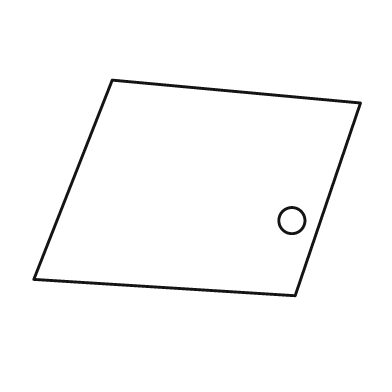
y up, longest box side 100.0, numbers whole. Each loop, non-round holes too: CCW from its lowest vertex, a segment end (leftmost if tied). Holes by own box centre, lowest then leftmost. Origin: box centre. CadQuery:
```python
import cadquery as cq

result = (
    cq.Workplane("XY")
    .moveTo(30.0, -33.0)
    .lineTo(50.0, 26.0)
    .lineTo(-26.0, 33.0)
    .lineTo(-50.0, -28.0)
    .close()
    .moveTo(29.0, -10.0)
    .circle(4.0)
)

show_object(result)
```